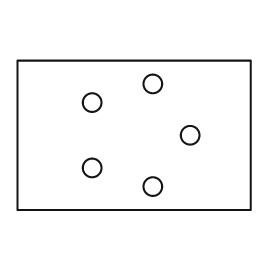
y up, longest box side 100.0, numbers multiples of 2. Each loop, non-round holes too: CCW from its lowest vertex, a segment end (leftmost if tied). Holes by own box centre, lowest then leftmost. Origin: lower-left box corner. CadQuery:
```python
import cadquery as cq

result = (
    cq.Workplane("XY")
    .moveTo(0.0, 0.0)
    .lineTo(100.0, 0.0)
    .lineTo(100.0, 64.0)
    .lineTo(0.0, 64.0)
    .close()
    .moveTo(58.0, 10.0)
    .circle(4.0)
    .moveTo(32.0, 18.0)
    .circle(4.0)
    .moveTo(74.0, 32.0)
    .circle(4.0)
    .moveTo(32.0, 46.0)
    .circle(4.0)
    .moveTo(58.0, 54.0)
    .circle(4.0)
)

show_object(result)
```